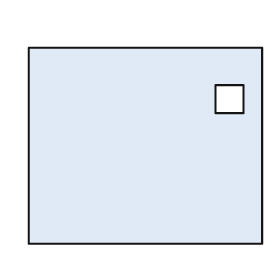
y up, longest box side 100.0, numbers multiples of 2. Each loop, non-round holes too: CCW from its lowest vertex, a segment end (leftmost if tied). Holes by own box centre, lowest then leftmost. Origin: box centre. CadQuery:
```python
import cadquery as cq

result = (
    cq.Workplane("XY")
    .moveTo(-50.0, -42.0)
    .lineTo(50.0, -42.0)
    .lineTo(50.0, 42.0)
    .lineTo(-50.0, 42.0)
    .close()
    .moveTo(30.0, 14.0)
    .lineTo(42.0, 14.0)
    .lineTo(42.0, 26.0)
    .lineTo(30.0, 26.0)
    .close()
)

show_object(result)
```